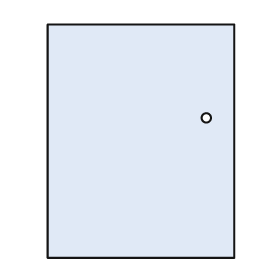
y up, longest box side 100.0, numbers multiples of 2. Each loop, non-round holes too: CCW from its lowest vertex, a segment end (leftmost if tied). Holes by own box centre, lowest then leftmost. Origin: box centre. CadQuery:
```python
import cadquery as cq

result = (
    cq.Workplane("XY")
    .moveTo(-40.0, -50.0)
    .lineTo(40.0, -50.0)
    .lineTo(40.0, 50.0)
    .lineTo(-40.0, 50.0)
    .close()
    .moveTo(28.0, 10.0)
    .circle(2.0)
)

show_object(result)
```